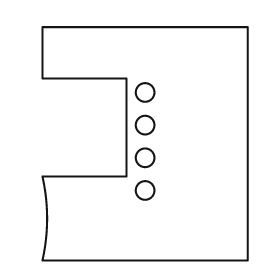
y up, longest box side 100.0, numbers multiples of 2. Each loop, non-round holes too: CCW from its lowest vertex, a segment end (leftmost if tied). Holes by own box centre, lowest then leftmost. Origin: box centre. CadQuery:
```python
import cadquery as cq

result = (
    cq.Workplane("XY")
    .moveTo(-44.0, -50.0)
    .lineTo(44.0, -50.0)
    .lineTo(44.0, 50.0)
    .lineTo(-44.0, 50.0)
    .lineTo(-44.0, 28.0)
    .lineTo(-8.0, 28.0)
    .lineTo(-8.0, -14.0)
    .lineTo(-44.0, -14.0)
    .threePointArc((-42.0, -32.0), (-44.0, -50.0))
    .close()
    .moveTo(0.0, -20.0)
    .circle(4.0)
    .moveTo(0.0, -6.0)
    .circle(4.0)
    .moveTo(0.0, 8.0)
    .circle(4.0)
    .moveTo(0.0, 22.0)
    .circle(4.0)
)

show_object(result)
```